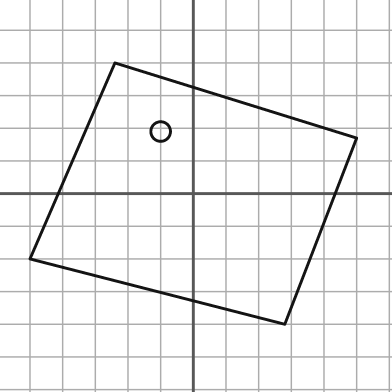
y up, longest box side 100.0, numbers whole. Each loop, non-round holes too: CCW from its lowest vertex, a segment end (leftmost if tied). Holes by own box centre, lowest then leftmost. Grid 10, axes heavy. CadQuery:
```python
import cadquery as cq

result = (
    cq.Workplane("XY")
    .moveTo(28.0, -40.0)
    .lineTo(50.0, 17.0)
    .lineTo(-24.0, 40.0)
    .lineTo(-50.0, -20.0)
    .close()
    .moveTo(-10.0, 19.0)
    .circle(3.0)
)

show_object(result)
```